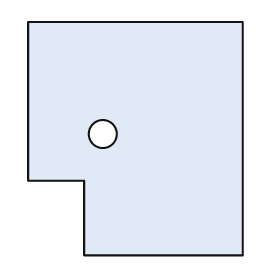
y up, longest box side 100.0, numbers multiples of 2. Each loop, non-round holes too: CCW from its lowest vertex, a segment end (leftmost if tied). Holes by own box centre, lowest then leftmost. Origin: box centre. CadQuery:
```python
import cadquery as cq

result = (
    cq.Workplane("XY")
    .moveTo(-22.0, -50.0)
    .lineTo(46.0, -50.0)
    .lineTo(46.0, 50.0)
    .lineTo(-46.0, 50.0)
    .lineTo(-46.0, -18.0)
    .lineTo(-22.0, -18.0)
    .close()
    .moveTo(-14.0, 2.0)
    .circle(6.0)
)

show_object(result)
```